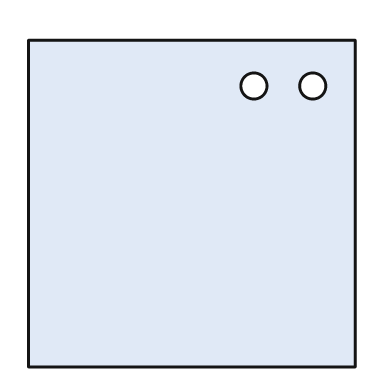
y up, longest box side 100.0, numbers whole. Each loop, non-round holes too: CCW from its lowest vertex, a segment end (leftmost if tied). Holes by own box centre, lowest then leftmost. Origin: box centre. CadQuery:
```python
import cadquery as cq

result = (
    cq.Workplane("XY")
    .moveTo(-50.0, -50.0)
    .lineTo(50.0, -50.0)
    .lineTo(50.0, 50.0)
    .lineTo(-50.0, 50.0)
    .close()
    .moveTo(19.0, 36.0)
    .circle(4.0)
    .moveTo(37.0, 36.0)
    .circle(4.0)
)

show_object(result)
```